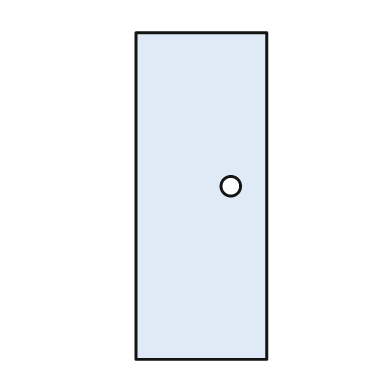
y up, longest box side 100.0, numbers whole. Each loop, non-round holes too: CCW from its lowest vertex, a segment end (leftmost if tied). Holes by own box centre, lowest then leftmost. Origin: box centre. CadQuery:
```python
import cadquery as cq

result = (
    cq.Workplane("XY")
    .moveTo(-20.0, -50.0)
    .lineTo(20.0, -50.0)
    .lineTo(20.0, 50.0)
    .lineTo(-20.0, 50.0)
    .close()
    .moveTo(9.0, 3.0)
    .circle(3.0)
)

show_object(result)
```